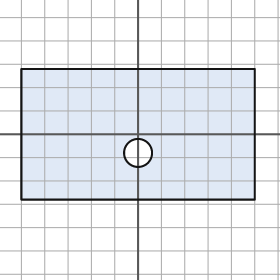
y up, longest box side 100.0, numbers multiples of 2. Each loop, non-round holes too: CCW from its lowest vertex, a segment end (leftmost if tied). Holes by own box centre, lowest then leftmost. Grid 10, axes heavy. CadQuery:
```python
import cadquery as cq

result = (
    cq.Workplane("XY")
    .moveTo(-50.0, -28.0)
    .lineTo(50.0, -28.0)
    .lineTo(50.0, 28.0)
    .lineTo(-50.0, 28.0)
    .close()
    .moveTo(0.0, -8.0)
    .circle(6.0)
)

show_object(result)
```